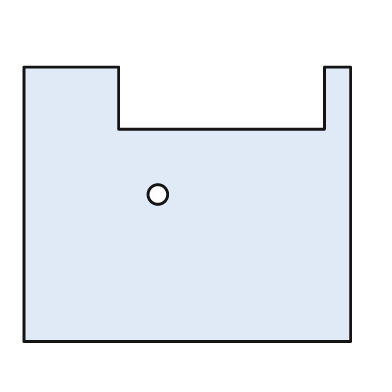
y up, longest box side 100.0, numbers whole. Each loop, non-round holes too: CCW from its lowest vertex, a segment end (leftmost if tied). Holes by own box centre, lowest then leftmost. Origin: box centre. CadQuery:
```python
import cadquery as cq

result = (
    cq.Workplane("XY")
    .moveTo(-50.0, -42.0)
    .lineTo(50.0, -42.0)
    .lineTo(50.0, 42.0)
    .lineTo(42.0, 42.0)
    .lineTo(42.0, 23.0)
    .lineTo(-21.0, 23.0)
    .lineTo(-21.0, 42.0)
    .lineTo(-50.0, 42.0)
    .close()
    .moveTo(-9.0, 3.0)
    .circle(3.0)
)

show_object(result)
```